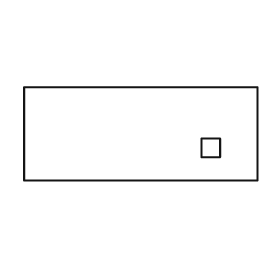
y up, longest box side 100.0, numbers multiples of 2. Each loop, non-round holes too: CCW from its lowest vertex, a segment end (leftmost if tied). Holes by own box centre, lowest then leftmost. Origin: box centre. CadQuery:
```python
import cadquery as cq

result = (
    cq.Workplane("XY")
    .moveTo(-50.0, -20.0)
    .lineTo(50.0, -20.0)
    .lineTo(50.0, 20.0)
    .lineTo(-50.0, 20.0)
    .close()
    .moveTo(26.0, -10.0)
    .lineTo(34.0, -10.0)
    .lineTo(34.0, -2.0)
    .lineTo(26.0, -2.0)
    .close()
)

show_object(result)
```